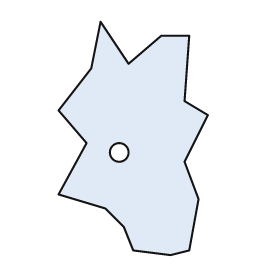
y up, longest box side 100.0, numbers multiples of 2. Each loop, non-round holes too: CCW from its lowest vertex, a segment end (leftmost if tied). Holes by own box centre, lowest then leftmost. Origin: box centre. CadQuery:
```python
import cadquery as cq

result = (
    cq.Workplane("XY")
    .moveTo(16.0, -50.0)
    .lineTo(24.0, -48.0)
    .lineTo(28.0, -26.0)
    .lineTo(22.0, -10.0)
    .lineTo(32.0, 10.0)
    .lineTo(22.0, 16.0)
    .lineTo(24.0, 44.0)
    .lineTo(12.0, 44.0)
    .lineTo(-2.0, 32.0)
    .lineTo(-14.0, 50.0)
    .lineTo(-18.0, 30.0)
    .lineTo(-32.0, 12.0)
    .lineTo(-20.0, -2.0)
    .lineTo(-32.0, -24.0)
    .lineTo(-12.0, -30.0)
    .lineTo(-4.0, -38.0)
    .lineTo(0.0, -48.0)
    .close()
    .moveTo(-6.0, -6.0)
    .circle(4.0)
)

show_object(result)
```